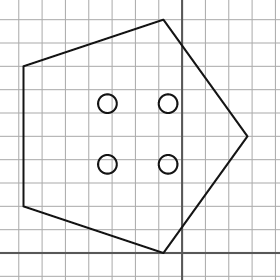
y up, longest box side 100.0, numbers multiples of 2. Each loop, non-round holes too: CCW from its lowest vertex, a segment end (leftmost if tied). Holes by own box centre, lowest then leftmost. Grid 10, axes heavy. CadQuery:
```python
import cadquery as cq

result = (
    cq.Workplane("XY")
    .moveTo(-8.0, 0.0)
    .lineTo(28.0, 50.0)
    .lineTo(-8.0, 100.0)
    .lineTo(-68.0, 80.0)
    .lineTo(-68.0, 20.0)
    .close()
    .moveTo(-32.0, 38.0)
    .circle(4.0)
    .moveTo(-6.0, 38.0)
    .circle(4.0)
    .moveTo(-32.0, 64.0)
    .circle(4.0)
    .moveTo(-6.0, 64.0)
    .circle(4.0)
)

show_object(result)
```